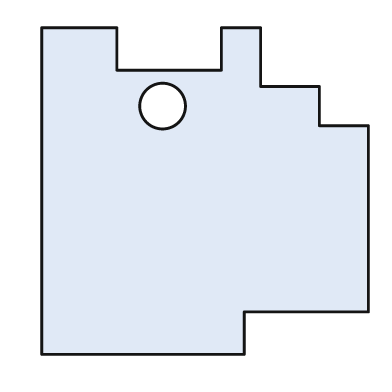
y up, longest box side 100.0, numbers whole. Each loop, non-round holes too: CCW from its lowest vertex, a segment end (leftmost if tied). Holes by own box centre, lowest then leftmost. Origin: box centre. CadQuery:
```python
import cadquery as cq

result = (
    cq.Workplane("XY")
    .moveTo(-50.0, -50.0)
    .lineTo(12.0, -50.0)
    .lineTo(12.0, -37.0)
    .lineTo(50.0, -37.0)
    .lineTo(50.0, 20.0)
    .lineTo(35.0, 20.0)
    .lineTo(35.0, 32.0)
    .lineTo(17.0, 32.0)
    .lineTo(17.0, 50.0)
    .lineTo(5.0, 50.0)
    .lineTo(5.0, 37.0)
    .lineTo(-27.0, 37.0)
    .lineTo(-27.0, 50.0)
    .lineTo(-50.0, 50.0)
    .close()
    .moveTo(-13.0, 26.0)
    .circle(7.0)
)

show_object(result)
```